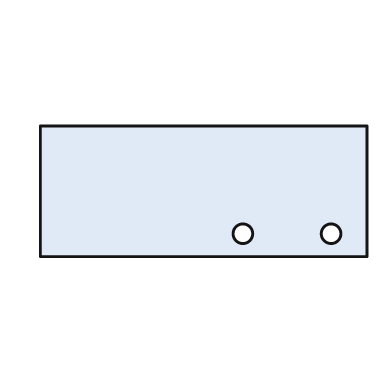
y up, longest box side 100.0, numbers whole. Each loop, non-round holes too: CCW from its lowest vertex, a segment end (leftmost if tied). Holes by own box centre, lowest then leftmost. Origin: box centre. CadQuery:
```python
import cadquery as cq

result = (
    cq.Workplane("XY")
    .moveTo(-50.0, -20.0)
    .lineTo(50.0, -20.0)
    .lineTo(50.0, 20.0)
    .lineTo(-50.0, 20.0)
    .close()
    .moveTo(12.0, -13.0)
    .circle(3.0)
    .moveTo(39.0, -13.0)
    .circle(3.0)
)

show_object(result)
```